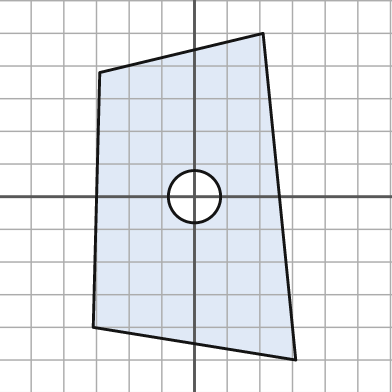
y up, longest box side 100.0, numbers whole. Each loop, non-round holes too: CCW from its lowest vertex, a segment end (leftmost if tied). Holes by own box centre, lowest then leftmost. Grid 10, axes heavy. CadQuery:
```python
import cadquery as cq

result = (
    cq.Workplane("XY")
    .moveTo(31.0, -50.0)
    .lineTo(21.0, 50.0)
    .lineTo(-29.0, 38.0)
    .lineTo(-31.0, -40.0)
    .close()
    .moveTo(0.0, 0.0)
    .circle(8.0)
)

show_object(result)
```